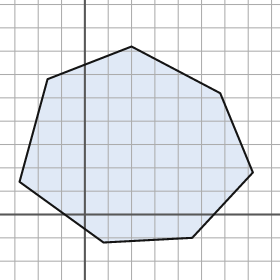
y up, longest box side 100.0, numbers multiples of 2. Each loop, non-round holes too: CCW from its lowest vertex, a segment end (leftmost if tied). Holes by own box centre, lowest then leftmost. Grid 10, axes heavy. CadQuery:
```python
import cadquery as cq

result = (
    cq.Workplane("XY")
    .moveTo(8.0, -12.0)
    .lineTo(46.0, -10.0)
    .lineTo(72.0, 18.0)
    .lineTo(58.0, 52.0)
    .lineTo(20.0, 72.0)
    .lineTo(-16.0, 58.0)
    .lineTo(-28.0, 14.0)
    .close()
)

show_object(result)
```